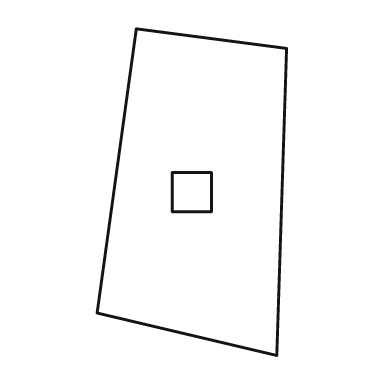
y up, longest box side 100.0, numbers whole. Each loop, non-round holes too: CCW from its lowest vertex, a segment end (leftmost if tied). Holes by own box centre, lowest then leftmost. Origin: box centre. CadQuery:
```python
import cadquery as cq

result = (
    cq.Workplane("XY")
    .moveTo(26.0, -50.0)
    .lineTo(29.0, 44.0)
    .lineTo(-17.0, 50.0)
    .lineTo(-29.0, -37.0)
    .close()
    .moveTo(-6.0, -6.0)
    .lineTo(6.0, -6.0)
    .lineTo(6.0, 6.0)
    .lineTo(-6.0, 6.0)
    .close()
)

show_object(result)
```